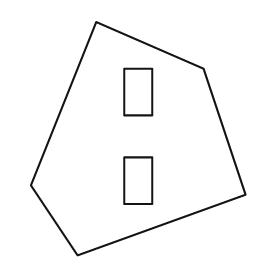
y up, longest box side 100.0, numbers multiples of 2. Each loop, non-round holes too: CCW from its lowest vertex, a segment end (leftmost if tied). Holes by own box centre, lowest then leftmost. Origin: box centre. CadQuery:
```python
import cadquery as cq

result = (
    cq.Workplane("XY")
    .moveTo(-26.0, -50.0)
    .lineTo(46.0, -24.0)
    .lineTo(28.0, 30.0)
    .lineTo(-18.0, 50.0)
    .lineTo(-46.0, -20.0)
    .close()
    .moveTo(-6.0, -28.0)
    .lineTo(6.0, -28.0)
    .lineTo(6.0, -8.0)
    .lineTo(-6.0, -8.0)
    .close()
    .moveTo(-6.0, 10.0)
    .lineTo(6.0, 10.0)
    .lineTo(6.0, 30.0)
    .lineTo(-6.0, 30.0)
    .close()
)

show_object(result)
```